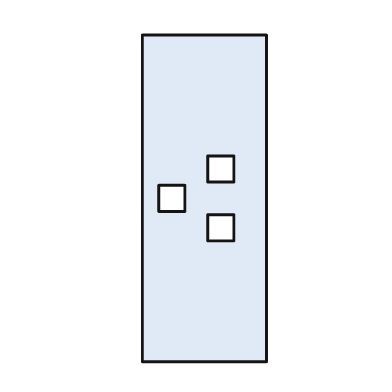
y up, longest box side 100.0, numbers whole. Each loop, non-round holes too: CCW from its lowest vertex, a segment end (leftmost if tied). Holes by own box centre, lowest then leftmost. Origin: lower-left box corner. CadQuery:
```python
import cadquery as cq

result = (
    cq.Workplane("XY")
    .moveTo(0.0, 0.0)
    .lineTo(38.0, 0.0)
    .lineTo(38.0, 100.0)
    .lineTo(0.0, 100.0)
    .close()
    .moveTo(20.0, 37.0)
    .lineTo(28.0, 37.0)
    .lineTo(28.0, 45.0)
    .lineTo(20.0, 45.0)
    .close()
    .moveTo(5.0, 46.0)
    .lineTo(13.0, 46.0)
    .lineTo(13.0, 54.0)
    .lineTo(5.0, 54.0)
    .close()
    .moveTo(20.0, 55.0)
    .lineTo(28.0, 55.0)
    .lineTo(28.0, 63.0)
    .lineTo(20.0, 63.0)
    .close()
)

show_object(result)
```